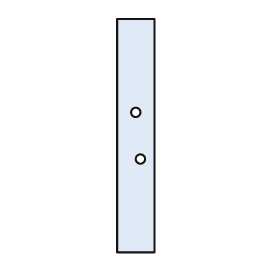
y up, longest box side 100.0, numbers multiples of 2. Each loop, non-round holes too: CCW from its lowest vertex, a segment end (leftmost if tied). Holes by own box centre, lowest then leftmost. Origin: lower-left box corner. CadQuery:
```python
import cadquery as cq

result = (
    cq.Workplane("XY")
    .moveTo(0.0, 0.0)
    .lineTo(16.0, 0.0)
    .lineTo(16.0, 100.0)
    .lineTo(0.0, 100.0)
    .close()
    .moveTo(10.0, 40.0)
    .circle(2.0)
    .moveTo(8.0, 60.0)
    .circle(2.0)
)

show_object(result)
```